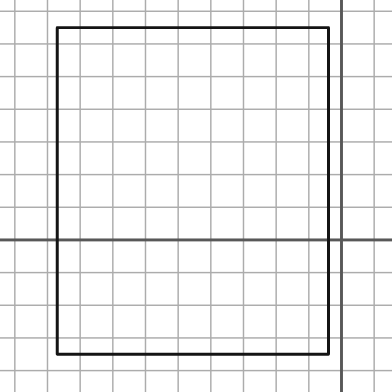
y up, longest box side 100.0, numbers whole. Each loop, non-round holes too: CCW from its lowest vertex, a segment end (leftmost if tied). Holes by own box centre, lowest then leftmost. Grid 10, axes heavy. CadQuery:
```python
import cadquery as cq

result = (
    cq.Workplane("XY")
    .moveTo(-87.0, -35.0)
    .lineTo(-4.0, -35.0)
    .lineTo(-4.0, 65.0)
    .lineTo(-87.0, 65.0)
    .close()
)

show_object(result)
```